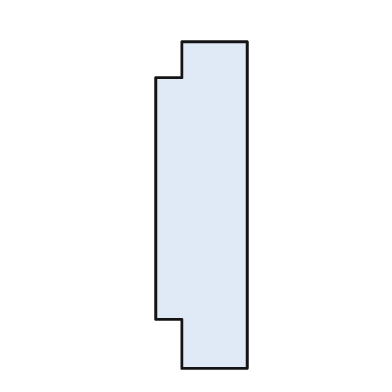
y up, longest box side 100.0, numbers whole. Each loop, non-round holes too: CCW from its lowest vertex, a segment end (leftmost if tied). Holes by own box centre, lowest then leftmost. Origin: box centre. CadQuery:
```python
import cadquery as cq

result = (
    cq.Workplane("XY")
    .moveTo(-6.0, -50.0)
    .lineTo(14.0, -50.0)
    .lineTo(14.0, 50.0)
    .lineTo(-6.0, 50.0)
    .lineTo(-6.0, 39.0)
    .lineTo(-14.0, 39.0)
    .lineTo(-14.0, -35.0)
    .lineTo(-6.0, -35.0)
    .close()
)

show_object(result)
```